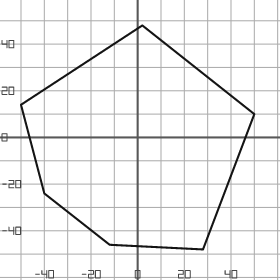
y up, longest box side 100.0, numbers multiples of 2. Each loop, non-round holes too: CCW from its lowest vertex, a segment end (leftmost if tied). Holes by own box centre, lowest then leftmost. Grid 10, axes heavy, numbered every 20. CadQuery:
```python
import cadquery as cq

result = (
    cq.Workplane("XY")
    .moveTo(28.0, -48.0)
    .lineTo(50.0, 10.0)
    .lineTo(2.0, 48.0)
    .lineTo(-50.0, 14.0)
    .lineTo(-40.0, -24.0)
    .lineTo(-12.0, -46.0)
    .close()
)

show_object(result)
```